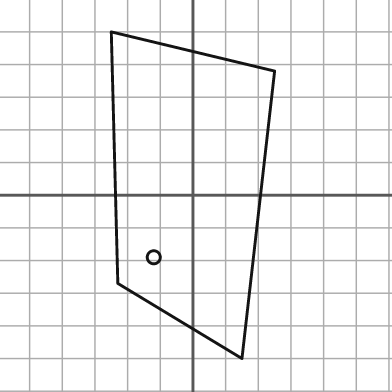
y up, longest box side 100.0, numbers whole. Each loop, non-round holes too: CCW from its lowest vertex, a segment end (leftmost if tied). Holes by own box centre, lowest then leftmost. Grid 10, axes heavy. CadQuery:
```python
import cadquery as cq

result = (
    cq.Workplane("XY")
    .moveTo(15.0, -50.0)
    .lineTo(25.0, 38.0)
    .lineTo(-25.0, 50.0)
    .lineTo(-23.0, -27.0)
    .close()
    .moveTo(-12.0, -19.0)
    .circle(2.0)
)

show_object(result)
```